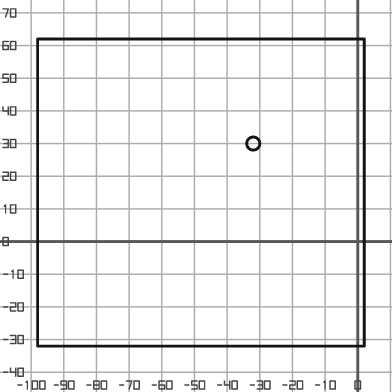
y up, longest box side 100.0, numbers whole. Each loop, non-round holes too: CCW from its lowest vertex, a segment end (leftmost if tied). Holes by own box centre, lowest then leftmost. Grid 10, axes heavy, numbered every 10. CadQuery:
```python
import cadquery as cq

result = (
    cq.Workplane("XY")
    .moveTo(-98.0, -32.0)
    .lineTo(2.0, -32.0)
    .lineTo(2.0, 62.0)
    .lineTo(-98.0, 62.0)
    .close()
    .moveTo(-32.0, 30.0)
    .circle(2.0)
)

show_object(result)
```